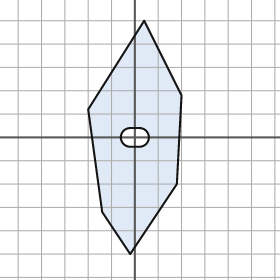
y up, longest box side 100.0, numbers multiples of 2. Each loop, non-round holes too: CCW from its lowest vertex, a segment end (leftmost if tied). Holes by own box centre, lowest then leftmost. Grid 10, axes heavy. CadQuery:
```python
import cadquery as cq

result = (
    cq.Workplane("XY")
    .moveTo(-2.0, -50.0)
    .lineTo(18.0, -20.0)
    .lineTo(20.0, 18.0)
    .lineTo(4.0, 50.0)
    .lineTo(-20.0, 12.0)
    .lineTo(-14.0, -32.0)
    .close()
    .moveTo(-2.0, -4.0)
    .lineTo(2.0, -4.0)
    .threePointArc((6.0, 0.0), (2.0, 4.0))
    .lineTo(-2.0, 4.0)
    .threePointArc((-6.0, 0.0), (-2.0, -4.0))
    .close()
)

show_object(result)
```